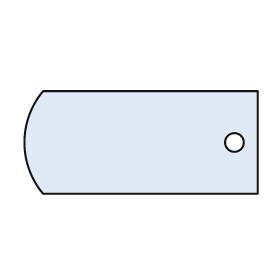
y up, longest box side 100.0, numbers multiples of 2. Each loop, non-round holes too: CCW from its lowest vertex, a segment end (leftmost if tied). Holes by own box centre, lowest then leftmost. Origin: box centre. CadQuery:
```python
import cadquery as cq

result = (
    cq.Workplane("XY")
    .moveTo(-42.0, -22.0)
    .lineTo(50.0, -22.0)
    .lineTo(50.0, 22.0)
    .lineTo(-42.0, 22.0)
    .threePointArc((-50.0, 0.0), (-42.0, -22.0))
    .close()
    .moveTo(40.0, 0.0)
    .circle(4.0)
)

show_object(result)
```